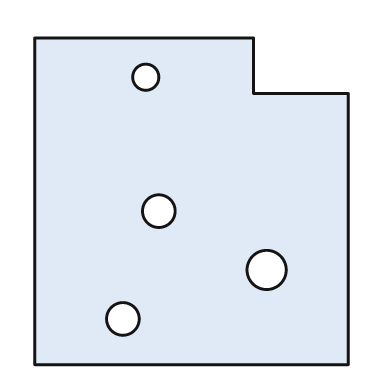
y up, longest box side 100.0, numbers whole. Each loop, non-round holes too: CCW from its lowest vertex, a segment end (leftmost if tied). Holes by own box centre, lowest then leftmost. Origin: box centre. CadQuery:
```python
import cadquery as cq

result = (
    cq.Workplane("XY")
    .moveTo(-48.0, -50.0)
    .lineTo(48.0, -50.0)
    .lineTo(48.0, 33.0)
    .lineTo(19.0, 33.0)
    .lineTo(19.0, 50.0)
    .lineTo(-48.0, 50.0)
    .close()
    .moveTo(-21.0, -36.0)
    .circle(5.0)
    .moveTo(23.0, -21.0)
    .circle(6.0)
    .moveTo(-10.0, -3.0)
    .circle(5.0)
    .moveTo(-14.0, 38.0)
    .circle(4.0)
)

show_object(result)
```